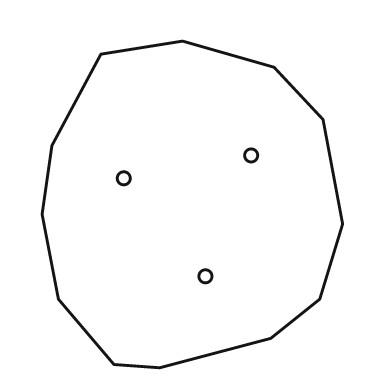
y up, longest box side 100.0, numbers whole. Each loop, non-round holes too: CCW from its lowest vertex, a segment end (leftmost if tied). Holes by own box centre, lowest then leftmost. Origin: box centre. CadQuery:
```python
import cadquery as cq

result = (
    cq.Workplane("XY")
    .moveTo(-10.0, -50.0)
    .lineTo(24.0, -41.0)
    .lineTo(39.0, -29.0)
    .lineTo(46.0, -6.0)
    .lineTo(40.0, 26.0)
    .lineTo(25.0, 42.0)
    .lineTo(-3.0, 50.0)
    .lineTo(-28.0, 46.0)
    .lineTo(-43.0, 18.0)
    .lineTo(-46.0, -3.0)
    .lineTo(-41.0, -29.0)
    .lineTo(-24.0, -49.0)
    .close()
    .moveTo(4.0, -22.0)
    .circle(2.0)
    .moveTo(-21.0, 8.0)
    .circle(2.0)
    .moveTo(18.0, 15.0)
    .circle(2.0)
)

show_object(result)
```